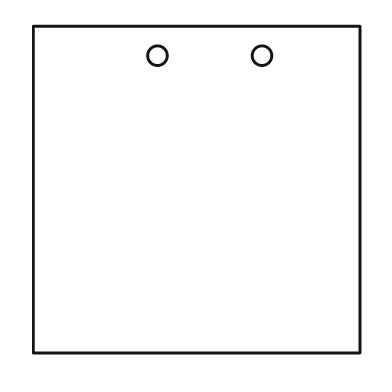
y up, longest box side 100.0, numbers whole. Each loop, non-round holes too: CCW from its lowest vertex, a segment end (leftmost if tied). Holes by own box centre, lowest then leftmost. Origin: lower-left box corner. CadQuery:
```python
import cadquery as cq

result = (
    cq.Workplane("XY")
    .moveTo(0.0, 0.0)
    .lineTo(100.0, 0.0)
    .lineTo(100.0, 100.0)
    .lineTo(0.0, 100.0)
    .close()
    .moveTo(38.0, 91.0)
    .circle(3.0)
    .moveTo(70.0, 91.0)
    .circle(3.0)
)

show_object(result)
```